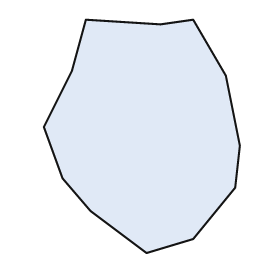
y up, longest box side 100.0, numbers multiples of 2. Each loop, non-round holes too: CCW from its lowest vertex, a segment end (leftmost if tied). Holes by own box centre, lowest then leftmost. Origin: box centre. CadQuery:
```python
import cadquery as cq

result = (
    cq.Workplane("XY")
    .moveTo(2.0, -50.0)
    .lineTo(22.0, -44.0)
    .lineTo(40.0, -22.0)
    .lineTo(42.0, -4.0)
    .lineTo(36.0, 26.0)
    .lineTo(22.0, 50.0)
    .lineTo(8.0, 48.0)
    .lineTo(-24.0, 50.0)
    .lineTo(-30.0, 28.0)
    .lineTo(-42.0, 4.0)
    .lineTo(-34.0, -18.0)
    .lineTo(-22.0, -32.0)
    .close()
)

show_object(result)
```